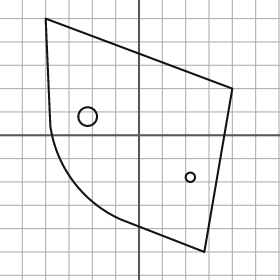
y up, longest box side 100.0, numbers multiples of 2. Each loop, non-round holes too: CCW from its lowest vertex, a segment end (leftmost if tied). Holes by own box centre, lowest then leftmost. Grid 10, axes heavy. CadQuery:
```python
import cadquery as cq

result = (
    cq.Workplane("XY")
    .moveTo(28.0, -50.0)
    .lineTo(40.0, 20.0)
    .lineTo(-40.0, 50.0)
    .lineTo(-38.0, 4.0)
    .threePointArc((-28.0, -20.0), (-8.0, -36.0))
    .close()
    .moveTo(22.0, -18.0)
    .circle(2.0)
    .moveTo(-22.0, 8.0)
    .circle(4.0)
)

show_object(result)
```